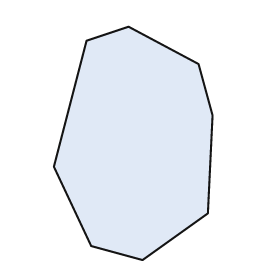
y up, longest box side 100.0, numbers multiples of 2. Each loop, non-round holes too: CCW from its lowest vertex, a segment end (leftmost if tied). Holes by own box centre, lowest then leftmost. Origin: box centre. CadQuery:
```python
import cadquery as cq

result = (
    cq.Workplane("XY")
    .moveTo(4.0, -50.0)
    .lineTo(32.0, -30.0)
    .lineTo(34.0, 12.0)
    .lineTo(28.0, 34.0)
    .lineTo(-2.0, 50.0)
    .lineTo(-20.0, 44.0)
    .lineTo(-34.0, -10.0)
    .lineTo(-18.0, -44.0)
    .close()
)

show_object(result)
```